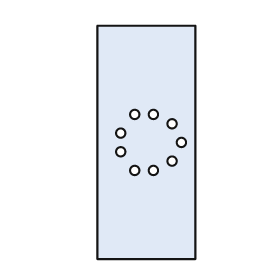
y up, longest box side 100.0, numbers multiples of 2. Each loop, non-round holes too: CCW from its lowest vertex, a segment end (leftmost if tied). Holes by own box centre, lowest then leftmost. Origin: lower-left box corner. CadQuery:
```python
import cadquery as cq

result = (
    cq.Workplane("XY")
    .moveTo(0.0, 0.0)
    .lineTo(42.0, 0.0)
    .lineTo(42.0, 100.0)
    .lineTo(0.0, 100.0)
    .close()
    .moveTo(16.0, 38.0)
    .circle(2.0)
    .moveTo(24.0, 38.0)
    .circle(2.0)
    .moveTo(32.0, 42.0)
    .circle(2.0)
    .moveTo(10.0, 46.0)
    .circle(2.0)
    .moveTo(36.0, 50.0)
    .circle(2.0)
    .moveTo(10.0, 54.0)
    .circle(2.0)
    .moveTo(32.0, 58.0)
    .circle(2.0)
    .moveTo(16.0, 62.0)
    .circle(2.0)
    .moveTo(24.0, 62.0)
    .circle(2.0)
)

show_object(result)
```